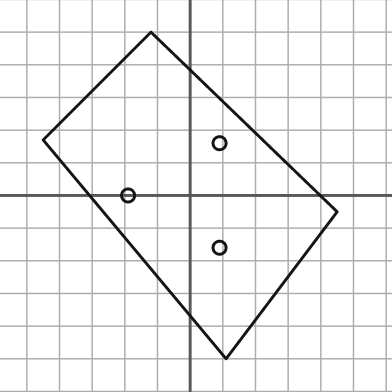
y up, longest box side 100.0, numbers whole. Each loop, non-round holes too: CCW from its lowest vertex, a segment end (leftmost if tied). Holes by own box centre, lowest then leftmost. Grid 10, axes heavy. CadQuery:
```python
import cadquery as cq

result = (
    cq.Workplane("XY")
    .moveTo(11.0, -50.0)
    .lineTo(45.0, -5.0)
    .lineTo(-12.0, 50.0)
    .lineTo(-45.0, 17.0)
    .close()
    .moveTo(9.0, -16.0)
    .circle(2.0)
    .moveTo(-19.0, 0.0)
    .circle(2.0)
    .moveTo(9.0, 16.0)
    .circle(2.0)
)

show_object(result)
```